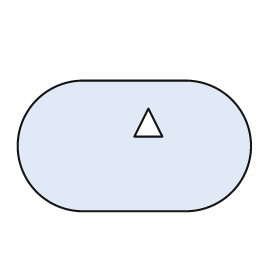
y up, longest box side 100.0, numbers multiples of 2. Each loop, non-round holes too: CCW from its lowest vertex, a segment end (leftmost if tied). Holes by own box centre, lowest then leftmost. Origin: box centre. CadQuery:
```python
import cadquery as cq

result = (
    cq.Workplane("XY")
    .moveTo(-22.0, -28.0)
    .lineTo(22.0, -28.0)
    .threePointArc((50.0, 0.0), (22.0, 28.0))
    .lineTo(-22.0, 28.0)
    .threePointArc((-50.0, 0.0), (-22.0, -28.0))
    .close()
    .moveTo(0.0, 4.0)
    .lineTo(12.0, 4.0)
    .lineTo(6.0, 16.0)
    .close()
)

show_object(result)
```